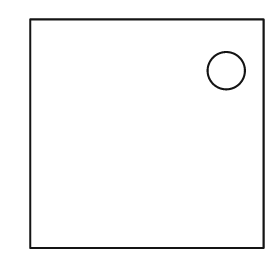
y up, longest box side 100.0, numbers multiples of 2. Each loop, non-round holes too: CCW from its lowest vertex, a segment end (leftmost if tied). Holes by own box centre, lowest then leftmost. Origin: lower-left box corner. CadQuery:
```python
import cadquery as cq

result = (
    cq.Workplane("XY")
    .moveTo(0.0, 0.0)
    .lineTo(100.0, 0.0)
    .lineTo(100.0, 98.0)
    .lineTo(0.0, 98.0)
    .close()
    .moveTo(84.0, 76.0)
    .circle(8.0)
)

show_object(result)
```